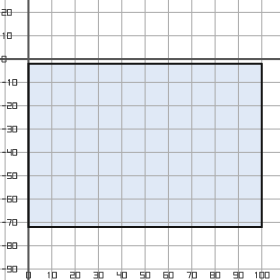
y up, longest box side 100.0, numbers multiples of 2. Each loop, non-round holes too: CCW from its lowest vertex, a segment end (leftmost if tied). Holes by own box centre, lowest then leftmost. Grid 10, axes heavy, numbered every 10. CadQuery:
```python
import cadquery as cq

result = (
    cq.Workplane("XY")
    .moveTo(0.0, -72.0)
    .lineTo(100.0, -72.0)
    .lineTo(100.0, -2.0)
    .lineTo(0.0, -2.0)
    .close()
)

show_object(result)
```